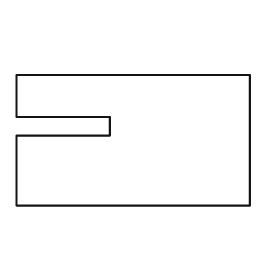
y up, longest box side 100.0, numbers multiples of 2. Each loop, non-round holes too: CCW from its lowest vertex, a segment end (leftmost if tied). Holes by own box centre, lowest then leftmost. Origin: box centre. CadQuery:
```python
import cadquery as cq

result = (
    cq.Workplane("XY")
    .moveTo(-50.0, -28.0)
    .lineTo(50.0, -28.0)
    .lineTo(50.0, 28.0)
    .lineTo(-50.0, 28.0)
    .lineTo(-50.0, 10.0)
    .lineTo(-10.0, 10.0)
    .lineTo(-10.0, 2.0)
    .lineTo(-50.0, 2.0)
    .close()
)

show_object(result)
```